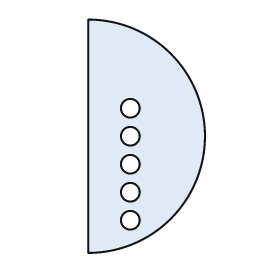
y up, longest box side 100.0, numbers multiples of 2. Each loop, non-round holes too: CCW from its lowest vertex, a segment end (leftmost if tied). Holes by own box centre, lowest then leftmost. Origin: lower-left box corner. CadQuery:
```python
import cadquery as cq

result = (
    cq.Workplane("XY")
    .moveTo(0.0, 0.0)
    .threePointArc((50.0, 50.0), (0.0, 100.0))
    .close()
    .moveTo(18.0, 14.0)
    .circle(4.0)
    .moveTo(18.0, 26.0)
    .circle(4.0)
    .moveTo(18.0, 38.0)
    .circle(4.0)
    .moveTo(18.0, 50.0)
    .circle(4.0)
    .moveTo(18.0, 62.0)
    .circle(4.0)
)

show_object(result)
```